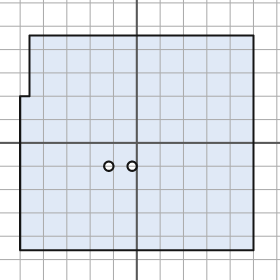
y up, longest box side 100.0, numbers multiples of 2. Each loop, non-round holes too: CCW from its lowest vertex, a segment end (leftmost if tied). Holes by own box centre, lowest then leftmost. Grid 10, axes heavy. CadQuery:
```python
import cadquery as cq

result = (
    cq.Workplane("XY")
    .moveTo(-50.0, -46.0)
    .lineTo(50.0, -46.0)
    .lineTo(50.0, 46.0)
    .lineTo(-46.0, 46.0)
    .lineTo(-46.0, 20.0)
    .lineTo(-50.0, 20.0)
    .close()
    .moveTo(-12.0, -10.0)
    .circle(2.0)
    .moveTo(-2.0, -10.0)
    .circle(2.0)
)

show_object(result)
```